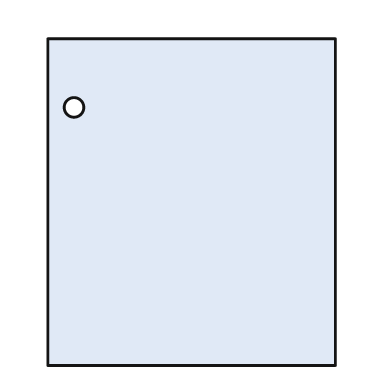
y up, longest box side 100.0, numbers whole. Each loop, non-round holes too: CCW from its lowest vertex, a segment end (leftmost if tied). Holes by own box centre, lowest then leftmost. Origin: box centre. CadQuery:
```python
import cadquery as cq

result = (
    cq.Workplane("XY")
    .moveTo(-44.0, -50.0)
    .lineTo(44.0, -50.0)
    .lineTo(44.0, 50.0)
    .lineTo(-44.0, 50.0)
    .close()
    .moveTo(-36.0, 29.0)
    .circle(3.0)
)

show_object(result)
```